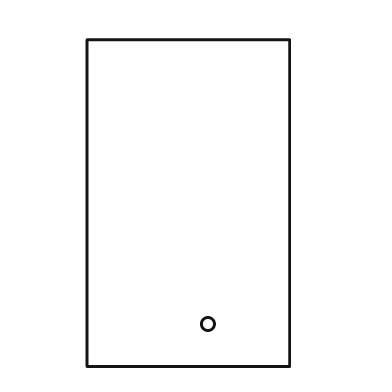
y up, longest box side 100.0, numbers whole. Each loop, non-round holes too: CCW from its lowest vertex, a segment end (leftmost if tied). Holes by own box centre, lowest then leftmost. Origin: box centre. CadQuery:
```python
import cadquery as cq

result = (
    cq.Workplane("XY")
    .moveTo(-31.0, -50.0)
    .lineTo(31.0, -50.0)
    .lineTo(31.0, 50.0)
    .lineTo(-31.0, 50.0)
    .close()
    .moveTo(6.0, -37.0)
    .circle(2.0)
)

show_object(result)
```